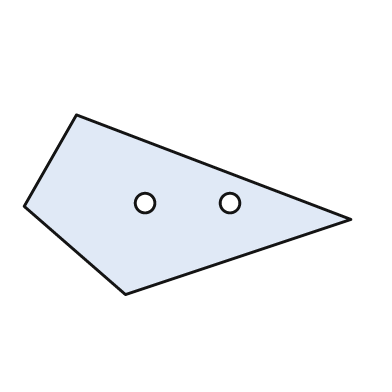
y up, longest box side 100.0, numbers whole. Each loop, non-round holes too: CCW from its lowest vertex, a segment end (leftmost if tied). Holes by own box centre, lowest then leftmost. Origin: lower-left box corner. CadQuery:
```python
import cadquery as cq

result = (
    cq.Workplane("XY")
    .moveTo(31.0, 0.0)
    .lineTo(100.0, 23.0)
    .lineTo(16.0, 55.0)
    .lineTo(0.0, 27.0)
    .close()
    .moveTo(37.0, 28.0)
    .circle(3.0)
    .moveTo(63.0, 28.0)
    .circle(3.0)
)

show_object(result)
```